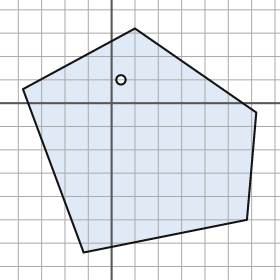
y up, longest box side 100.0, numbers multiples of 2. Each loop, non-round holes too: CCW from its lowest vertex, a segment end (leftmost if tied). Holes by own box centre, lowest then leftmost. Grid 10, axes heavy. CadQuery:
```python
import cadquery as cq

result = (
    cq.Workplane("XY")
    .moveTo(-12.0, -64.0)
    .lineTo(58.0, -50.0)
    .lineTo(62.0, -4.0)
    .lineTo(10.0, 32.0)
    .lineTo(-38.0, 6.0)
    .close()
    .moveTo(4.0, 10.0)
    .circle(2.0)
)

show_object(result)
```